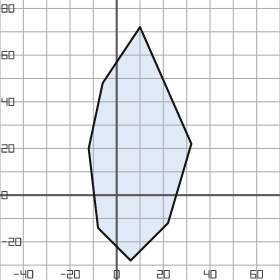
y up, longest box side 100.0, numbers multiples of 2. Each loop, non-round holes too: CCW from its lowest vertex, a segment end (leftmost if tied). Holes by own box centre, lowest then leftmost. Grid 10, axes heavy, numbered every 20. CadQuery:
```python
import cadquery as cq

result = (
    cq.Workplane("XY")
    .moveTo(6.0, -28.0)
    .lineTo(22.0, -12.0)
    .lineTo(32.0, 22.0)
    .lineTo(10.0, 72.0)
    .lineTo(-6.0, 48.0)
    .lineTo(-12.0, 20.0)
    .lineTo(-8.0, -14.0)
    .close()
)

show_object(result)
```